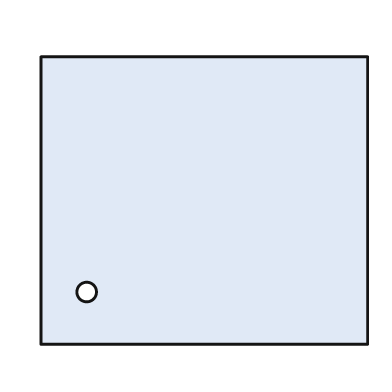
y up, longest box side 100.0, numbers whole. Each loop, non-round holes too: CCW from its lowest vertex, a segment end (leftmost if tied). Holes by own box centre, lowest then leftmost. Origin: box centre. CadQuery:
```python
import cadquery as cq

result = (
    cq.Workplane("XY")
    .moveTo(-50.0, -44.0)
    .lineTo(50.0, -44.0)
    .lineTo(50.0, 44.0)
    .lineTo(-50.0, 44.0)
    .close()
    .moveTo(-36.0, -28.0)
    .circle(3.0)
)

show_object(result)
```